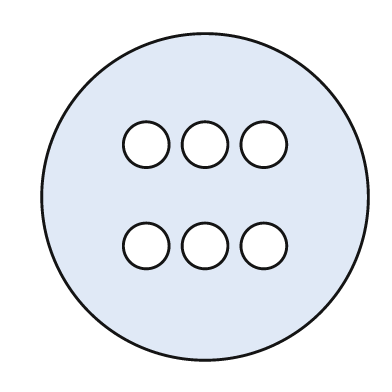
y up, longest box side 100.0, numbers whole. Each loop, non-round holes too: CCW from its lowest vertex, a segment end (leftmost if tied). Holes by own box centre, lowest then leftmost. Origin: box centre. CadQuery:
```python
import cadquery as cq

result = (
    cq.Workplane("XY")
    .moveTo(0.0, 0.0)
    .circle(50.0)
    .moveTo(-18.0, -15.0)
    .circle(7.0)
    .moveTo(0.0, -15.0)
    .circle(7.0)
    .moveTo(18.0, -15.0)
    .circle(7.0)
    .moveTo(-18.0, 16.0)
    .circle(7.0)
    .moveTo(0.0, 16.0)
    .circle(7.0)
    .moveTo(18.0, 16.0)
    .circle(7.0)
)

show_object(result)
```